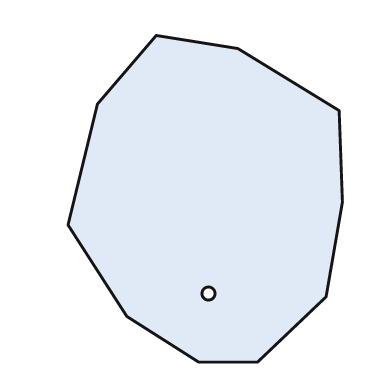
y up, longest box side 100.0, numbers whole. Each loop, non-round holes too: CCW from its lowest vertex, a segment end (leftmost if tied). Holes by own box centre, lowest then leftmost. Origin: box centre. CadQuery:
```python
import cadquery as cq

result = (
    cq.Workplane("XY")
    .moveTo(-2.0, -50.0)
    .lineTo(16.0, -50.0)
    .lineTo(37.0, -30.0)
    .lineTo(42.0, -1.0)
    .lineTo(41.0, 27.0)
    .lineTo(10.0, 46.0)
    .lineTo(-15.0, 50.0)
    .lineTo(-33.0, 29.0)
    .lineTo(-42.0, -8.0)
    .lineTo(-24.0, -36.0)
    .close()
    .moveTo(1.0, -29.0)
    .circle(2.0)
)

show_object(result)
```